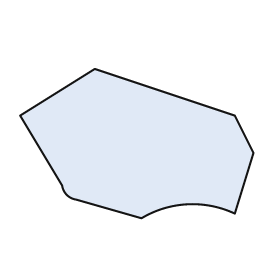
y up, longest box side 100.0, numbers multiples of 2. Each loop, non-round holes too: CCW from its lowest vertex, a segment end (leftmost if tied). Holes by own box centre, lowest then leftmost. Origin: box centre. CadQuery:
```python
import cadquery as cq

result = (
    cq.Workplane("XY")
    .moveTo(2.0, -32.0)
    .threePointArc((22.0, -26.0), (42.0, -30.0))
    .lineTo(50.0, -4.0)
    .lineTo(42.0, 12.0)
    .lineTo(-18.0, 32.0)
    .lineTo(-50.0, 12.0)
    .lineTo(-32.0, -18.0)
    .threePointArc((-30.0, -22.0), (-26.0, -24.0))
    .close()
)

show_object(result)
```